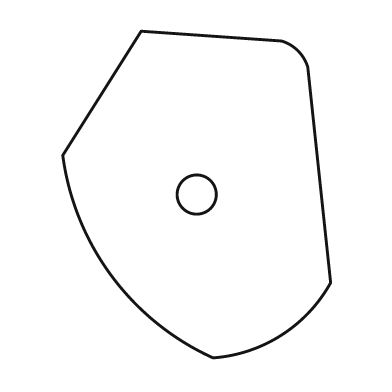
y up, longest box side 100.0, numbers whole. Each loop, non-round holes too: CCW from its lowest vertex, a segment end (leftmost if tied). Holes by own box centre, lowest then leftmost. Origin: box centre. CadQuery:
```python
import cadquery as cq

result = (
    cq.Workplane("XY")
    .moveTo(5.0, -50.0)
    .threePointArc((26.0, -43.0), (41.0, -27.0))
    .lineTo(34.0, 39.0)
    .threePointArc((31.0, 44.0), (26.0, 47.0))
    .lineTo(-17.0, 50.0)
    .lineTo(-41.0, 12.0)
    .threePointArc((-26.0, -25.0), (5.0, -50.0))
    .close()
    .moveTo(0.0, 0.0)
    .circle(6.0)
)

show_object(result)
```